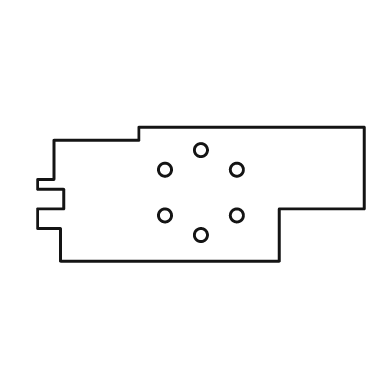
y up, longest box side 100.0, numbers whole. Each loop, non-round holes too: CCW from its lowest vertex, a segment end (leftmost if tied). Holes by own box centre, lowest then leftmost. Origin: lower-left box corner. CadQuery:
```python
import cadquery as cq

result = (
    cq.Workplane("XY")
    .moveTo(7.0, 0.0)
    .lineTo(74.0, 0.0)
    .lineTo(74.0, 16.0)
    .lineTo(100.0, 16.0)
    .lineTo(100.0, 41.0)
    .lineTo(31.0, 41.0)
    .lineTo(31.0, 37.0)
    .lineTo(5.0, 37.0)
    .lineTo(5.0, 25.0)
    .lineTo(0.0, 25.0)
    .lineTo(0.0, 22.0)
    .lineTo(8.0, 22.0)
    .lineTo(8.0, 16.0)
    .lineTo(0.0, 16.0)
    .lineTo(0.0, 10.0)
    .lineTo(7.0, 10.0)
    .close()
    .moveTo(50.0, 8.0)
    .circle(2.0)
    .moveTo(39.0, 14.0)
    .circle(2.0)
    .moveTo(61.0, 14.0)
    .circle(2.0)
    .moveTo(39.0, 28.0)
    .circle(2.0)
    .moveTo(61.0, 28.0)
    .circle(2.0)
    .moveTo(50.0, 34.0)
    .circle(2.0)
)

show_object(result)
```